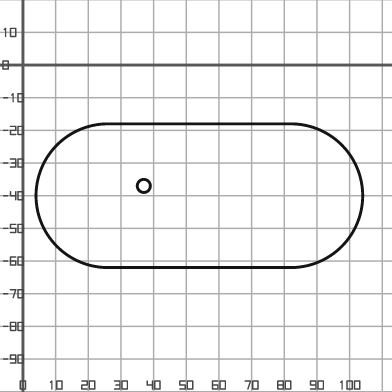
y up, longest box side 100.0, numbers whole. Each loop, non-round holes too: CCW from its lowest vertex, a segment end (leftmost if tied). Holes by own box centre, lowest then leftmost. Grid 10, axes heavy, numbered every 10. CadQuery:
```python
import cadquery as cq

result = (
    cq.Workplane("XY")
    .moveTo(26.0, -62.0)
    .lineTo(82.0, -62.0)
    .threePointArc((104.0, -40.0), (82.0, -18.0))
    .lineTo(26.0, -18.0)
    .threePointArc((4.0, -40.0), (26.0, -62.0))
    .close()
    .moveTo(37.0, -37.0)
    .circle(2.0)
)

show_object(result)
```